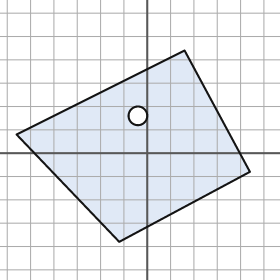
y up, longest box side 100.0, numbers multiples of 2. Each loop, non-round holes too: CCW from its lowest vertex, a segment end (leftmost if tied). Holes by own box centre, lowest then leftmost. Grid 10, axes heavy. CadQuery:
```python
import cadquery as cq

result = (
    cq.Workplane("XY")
    .moveTo(-12.0, -38.0)
    .lineTo(44.0, -8.0)
    .lineTo(16.0, 44.0)
    .lineTo(-56.0, 8.0)
    .close()
    .moveTo(-4.0, 16.0)
    .circle(4.0)
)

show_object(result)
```